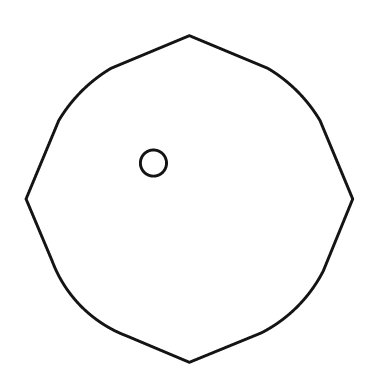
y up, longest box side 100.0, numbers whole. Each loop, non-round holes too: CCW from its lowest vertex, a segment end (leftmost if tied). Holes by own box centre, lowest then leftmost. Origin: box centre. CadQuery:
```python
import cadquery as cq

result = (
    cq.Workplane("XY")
    .moveTo(0.0, -50.0)
    .lineTo(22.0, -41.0)
    .threePointArc((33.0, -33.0), (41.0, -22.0))
    .lineTo(50.0, 0.0)
    .lineTo(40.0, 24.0)
    .threePointArc((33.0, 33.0), (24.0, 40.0))
    .lineTo(0.0, 50.0)
    .lineTo(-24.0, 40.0)
    .threePointArc((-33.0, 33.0), (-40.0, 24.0))
    .lineTo(-50.0, 0.0)
    .lineTo(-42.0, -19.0)
    .threePointArc((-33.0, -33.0), (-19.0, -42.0))
    .close()
    .moveTo(-11.0, 11.0)
    .circle(4.0)
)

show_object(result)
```